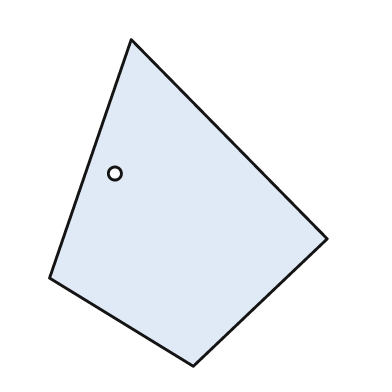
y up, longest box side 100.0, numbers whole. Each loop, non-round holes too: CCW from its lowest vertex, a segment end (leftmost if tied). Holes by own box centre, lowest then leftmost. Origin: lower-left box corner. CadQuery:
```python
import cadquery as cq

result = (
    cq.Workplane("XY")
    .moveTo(44.0, 0.0)
    .lineTo(85.0, 39.0)
    .lineTo(25.0, 100.0)
    .lineTo(0.0, 27.0)
    .close()
    .moveTo(20.0, 59.0)
    .circle(2.0)
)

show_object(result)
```